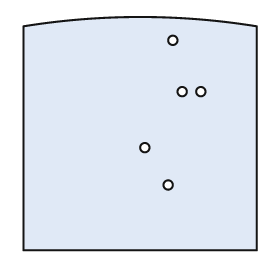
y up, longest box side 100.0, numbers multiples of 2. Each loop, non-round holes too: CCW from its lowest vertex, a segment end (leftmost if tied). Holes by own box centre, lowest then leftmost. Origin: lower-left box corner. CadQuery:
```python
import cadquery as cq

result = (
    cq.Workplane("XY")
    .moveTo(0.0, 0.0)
    .lineTo(100.0, 0.0)
    .lineTo(100.0, 96.0)
    .threePointArc((50.0, 100.0), (0.0, 96.0))
    .close()
    .moveTo(62.0, 28.0)
    .circle(2.0)
    .moveTo(52.0, 44.0)
    .circle(2.0)
    .moveTo(68.0, 68.0)
    .circle(2.0)
    .moveTo(76.0, 68.0)
    .circle(2.0)
    .moveTo(64.0, 90.0)
    .circle(2.0)
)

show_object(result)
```